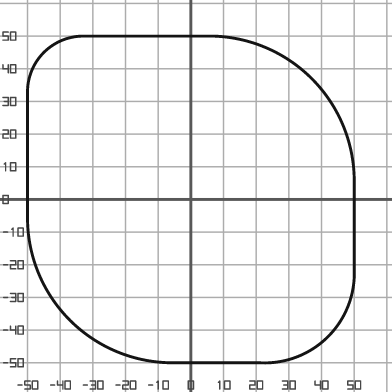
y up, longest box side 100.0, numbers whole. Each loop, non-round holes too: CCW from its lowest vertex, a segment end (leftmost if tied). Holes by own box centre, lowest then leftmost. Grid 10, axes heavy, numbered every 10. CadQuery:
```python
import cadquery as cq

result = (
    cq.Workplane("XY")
    .moveTo(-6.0, -50.0)
    .lineTo(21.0, -50.0)
    .threePointArc((42.0, -42.0), (50.0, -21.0))
    .lineTo(50.0, 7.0)
    .threePointArc((37.0, 37.0), (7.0, 50.0))
    .lineTo(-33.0, 50.0)
    .threePointArc((-45.0, 45.0), (-50.0, 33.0))
    .lineTo(-50.0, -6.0)
    .threePointArc((-37.0, -37.0), (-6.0, -50.0))
    .close()
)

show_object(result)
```